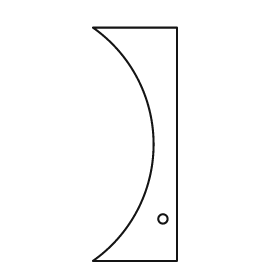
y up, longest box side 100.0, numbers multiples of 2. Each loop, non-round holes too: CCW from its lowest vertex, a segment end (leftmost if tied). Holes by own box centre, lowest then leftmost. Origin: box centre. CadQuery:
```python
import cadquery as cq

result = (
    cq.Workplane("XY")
    .moveTo(-18.0, -50.0)
    .lineTo(18.0, -50.0)
    .lineTo(18.0, 50.0)
    .lineTo(-18.0, 50.0)
    .threePointArc((8.0, 0.0), (-18.0, -50.0))
    .close()
    .moveTo(12.0, -32.0)
    .circle(2.0)
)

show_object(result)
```